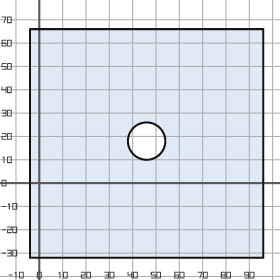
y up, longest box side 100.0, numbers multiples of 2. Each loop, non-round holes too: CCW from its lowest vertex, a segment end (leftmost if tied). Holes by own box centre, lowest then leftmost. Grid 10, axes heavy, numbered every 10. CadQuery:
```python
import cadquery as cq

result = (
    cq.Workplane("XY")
    .moveTo(-4.0, -32.0)
    .lineTo(96.0, -32.0)
    .lineTo(96.0, 66.0)
    .lineTo(-4.0, 66.0)
    .close()
    .moveTo(46.0, 18.0)
    .circle(8.0)
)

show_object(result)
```